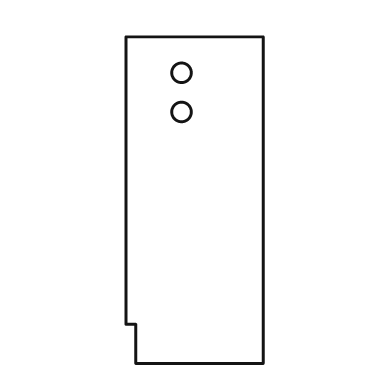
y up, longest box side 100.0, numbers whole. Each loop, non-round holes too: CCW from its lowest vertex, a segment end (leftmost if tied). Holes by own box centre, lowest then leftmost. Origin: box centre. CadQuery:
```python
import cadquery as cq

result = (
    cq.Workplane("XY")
    .moveTo(-18.0, -50.0)
    .lineTo(21.0, -50.0)
    .lineTo(21.0, 50.0)
    .lineTo(-21.0, 50.0)
    .lineTo(-21.0, -38.0)
    .lineTo(-18.0, -38.0)
    .close()
    .moveTo(-4.0, 27.0)
    .circle(3.0)
    .moveTo(-4.0, 39.0)
    .circle(3.0)
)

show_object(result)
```